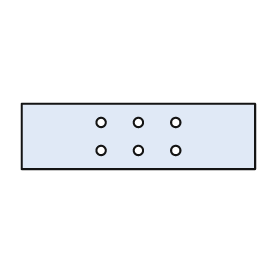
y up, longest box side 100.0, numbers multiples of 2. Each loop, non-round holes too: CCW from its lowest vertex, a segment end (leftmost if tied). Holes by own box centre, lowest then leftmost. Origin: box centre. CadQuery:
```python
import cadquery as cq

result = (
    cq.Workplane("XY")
    .moveTo(-50.0, -14.0)
    .lineTo(50.0, -14.0)
    .lineTo(50.0, 14.0)
    .lineTo(-50.0, 14.0)
    .close()
    .moveTo(-16.0, -6.0)
    .circle(2.0)
    .moveTo(0.0, -6.0)
    .circle(2.0)
    .moveTo(16.0, -6.0)
    .circle(2.0)
    .moveTo(-16.0, 6.0)
    .circle(2.0)
    .moveTo(0.0, 6.0)
    .circle(2.0)
    .moveTo(16.0, 6.0)
    .circle(2.0)
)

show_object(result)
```